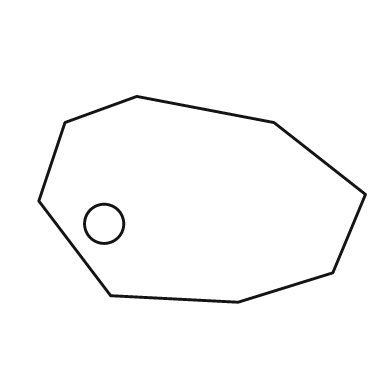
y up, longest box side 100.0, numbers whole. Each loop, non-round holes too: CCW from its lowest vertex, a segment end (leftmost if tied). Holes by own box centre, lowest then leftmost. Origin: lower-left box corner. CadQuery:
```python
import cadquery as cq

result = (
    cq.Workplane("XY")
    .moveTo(61.0, 0.0)
    .lineTo(90.0, 9.0)
    .lineTo(100.0, 33.0)
    .lineTo(72.0, 55.0)
    .lineTo(30.0, 63.0)
    .lineTo(8.0, 55.0)
    .lineTo(0.0, 31.0)
    .lineTo(22.0, 2.0)
    .close()
    .moveTo(20.0, 24.0)
    .circle(6.0)
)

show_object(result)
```